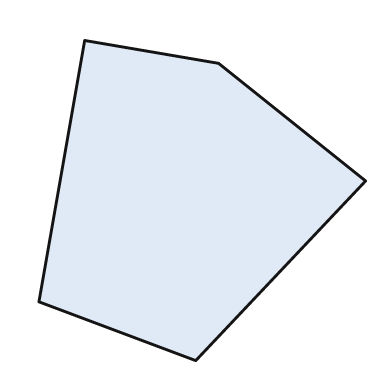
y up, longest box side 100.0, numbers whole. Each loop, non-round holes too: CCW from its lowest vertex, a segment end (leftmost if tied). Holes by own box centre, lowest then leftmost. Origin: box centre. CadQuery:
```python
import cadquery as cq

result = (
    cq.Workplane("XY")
    .moveTo(-2.0, -49.0)
    .lineTo(50.0, 6.0)
    .lineTo(5.0, 42.0)
    .lineTo(-36.0, 49.0)
    .lineTo(-50.0, -31.0)
    .close()
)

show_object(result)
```